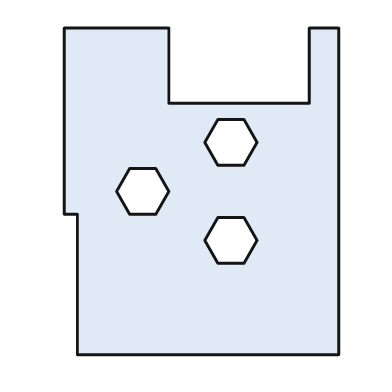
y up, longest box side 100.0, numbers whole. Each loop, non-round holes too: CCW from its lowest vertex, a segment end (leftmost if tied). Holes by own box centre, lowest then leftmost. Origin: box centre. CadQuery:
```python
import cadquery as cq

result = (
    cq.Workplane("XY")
    .moveTo(-38.0, -50.0)
    .lineTo(42.0, -50.0)
    .lineTo(42.0, 50.0)
    .lineTo(33.0, 50.0)
    .lineTo(33.0, 27.0)
    .lineTo(-10.0, 27.0)
    .lineTo(-10.0, 50.0)
    .lineTo(-42.0, 50.0)
    .lineTo(-42.0, -7.0)
    .lineTo(-38.0, -7.0)
    .close()
    .moveTo(5.0, -22.0)
    .lineTo(13.0, -22.0)
    .lineTo(17.0, -15.0)
    .lineTo(13.0, -8.0)
    .lineTo(5.0, -8.0)
    .lineTo(1.0, -15.0)
    .close()
    .moveTo(-22.0, -7.0)
    .lineTo(-14.0, -7.0)
    .lineTo(-10.0, 0.0)
    .lineTo(-14.0, 7.0)
    .lineTo(-22.0, 7.0)
    .lineTo(-26.0, 0.0)
    .close()
    .moveTo(5.0, 8.0)
    .lineTo(13.0, 8.0)
    .lineTo(17.0, 15.0)
    .lineTo(13.0, 22.0)
    .lineTo(5.0, 22.0)
    .lineTo(1.0, 15.0)
    .close()
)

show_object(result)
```